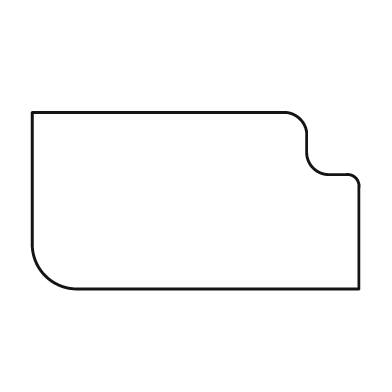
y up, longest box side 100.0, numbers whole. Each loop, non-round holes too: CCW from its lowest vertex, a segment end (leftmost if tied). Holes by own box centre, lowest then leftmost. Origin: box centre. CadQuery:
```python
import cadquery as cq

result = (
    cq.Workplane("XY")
    .moveTo(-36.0, -27.0)
    .lineTo(50.0, -27.0)
    .lineTo(50.0, 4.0)
    .threePointArc((49.0, 7.0), (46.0, 8.0))
    .lineTo(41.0, 8.0)
    .threePointArc((36.0, 10.0), (34.0, 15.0))
    .lineTo(34.0, 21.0)
    .threePointArc((32.0, 25.0), (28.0, 27.0))
    .lineTo(-50.0, 27.0)
    .lineTo(-50.0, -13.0)
    .threePointArc((-46.0, -23.0), (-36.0, -27.0))
    .close()
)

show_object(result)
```